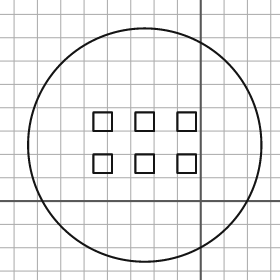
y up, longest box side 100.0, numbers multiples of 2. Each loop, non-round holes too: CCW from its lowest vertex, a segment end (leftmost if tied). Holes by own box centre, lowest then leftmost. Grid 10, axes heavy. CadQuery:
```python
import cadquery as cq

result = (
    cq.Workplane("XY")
    .moveTo(-24.0, 24.0)
    .circle(50.0)
    .moveTo(-46.0, 12.0)
    .lineTo(-38.0, 12.0)
    .lineTo(-38.0, 20.0)
    .lineTo(-46.0, 20.0)
    .close()
    .moveTo(-28.0, 12.0)
    .lineTo(-20.0, 12.0)
    .lineTo(-20.0, 20.0)
    .lineTo(-28.0, 20.0)
    .close()
    .moveTo(-10.0, 12.0)
    .lineTo(-2.0, 12.0)
    .lineTo(-2.0, 20.0)
    .lineTo(-10.0, 20.0)
    .close()
    .moveTo(-46.0, 30.0)
    .lineTo(-38.0, 30.0)
    .lineTo(-38.0, 38.0)
    .lineTo(-46.0, 38.0)
    .close()
    .moveTo(-28.0, 30.0)
    .lineTo(-20.0, 30.0)
    .lineTo(-20.0, 38.0)
    .lineTo(-28.0, 38.0)
    .close()
    .moveTo(-10.0, 30.0)
    .lineTo(-2.0, 30.0)
    .lineTo(-2.0, 38.0)
    .lineTo(-10.0, 38.0)
    .close()
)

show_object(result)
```